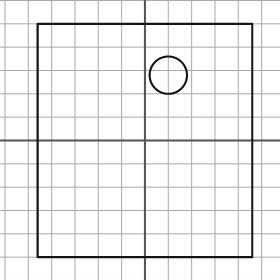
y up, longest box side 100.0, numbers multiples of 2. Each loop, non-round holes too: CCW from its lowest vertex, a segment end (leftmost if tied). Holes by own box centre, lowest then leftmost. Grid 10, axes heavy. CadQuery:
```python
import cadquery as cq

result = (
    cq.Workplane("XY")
    .moveTo(-46.0, -50.0)
    .lineTo(46.0, -50.0)
    .lineTo(46.0, 50.0)
    .lineTo(-46.0, 50.0)
    .close()
    .moveTo(10.0, 28.0)
    .circle(8.0)
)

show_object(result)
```